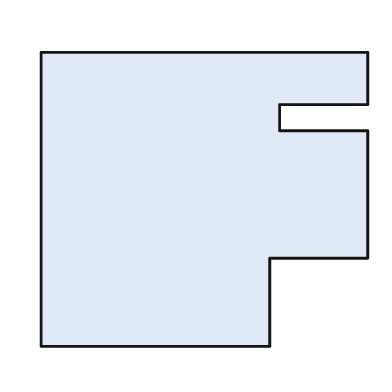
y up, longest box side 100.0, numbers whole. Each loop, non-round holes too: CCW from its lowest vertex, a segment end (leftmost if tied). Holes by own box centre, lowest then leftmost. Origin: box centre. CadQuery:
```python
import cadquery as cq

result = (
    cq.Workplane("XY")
    .moveTo(-50.0, -45.0)
    .lineTo(20.0, -45.0)
    .lineTo(20.0, -18.0)
    .lineTo(50.0, -18.0)
    .lineTo(50.0, 21.0)
    .lineTo(23.0, 21.0)
    .lineTo(23.0, 29.0)
    .lineTo(50.0, 29.0)
    .lineTo(50.0, 45.0)
    .lineTo(-50.0, 45.0)
    .close()
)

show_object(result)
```